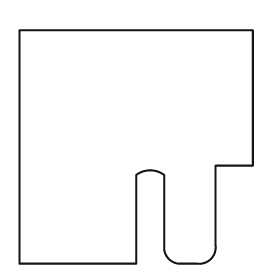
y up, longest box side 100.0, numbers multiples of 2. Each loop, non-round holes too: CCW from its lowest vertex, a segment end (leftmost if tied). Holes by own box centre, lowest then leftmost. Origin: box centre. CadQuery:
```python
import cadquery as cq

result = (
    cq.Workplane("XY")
    .moveTo(-50.0, -50.0)
    .lineTo(0.0, -50.0)
    .lineTo(0.0, -12.0)
    .threePointArc((6.0, -10.0), (12.0, -12.0))
    .lineTo(12.0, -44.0)
    .threePointArc((14.0, -48.0), (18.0, -50.0))
    .lineTo(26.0, -50.0)
    .threePointArc((32.0, -48.0), (34.0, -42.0))
    .lineTo(34.0, -8.0)
    .lineTo(50.0, -8.0)
    .lineTo(50.0, 50.0)
    .lineTo(-50.0, 50.0)
    .close()
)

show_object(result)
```